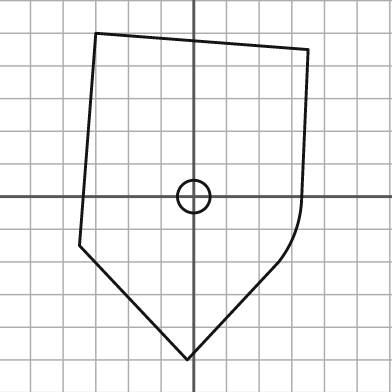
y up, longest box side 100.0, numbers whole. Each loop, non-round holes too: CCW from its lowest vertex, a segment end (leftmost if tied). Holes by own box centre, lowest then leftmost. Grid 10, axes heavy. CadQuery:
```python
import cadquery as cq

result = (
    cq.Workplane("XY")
    .moveTo(-2.0, -50.0)
    .lineTo(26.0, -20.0)
    .threePointArc((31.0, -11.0), (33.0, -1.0))
    .lineTo(35.0, 45.0)
    .lineTo(-30.0, 50.0)
    .lineTo(-35.0, -15.0)
    .close()
    .moveTo(0.0, 0.0)
    .circle(5.0)
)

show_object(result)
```